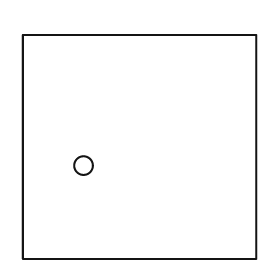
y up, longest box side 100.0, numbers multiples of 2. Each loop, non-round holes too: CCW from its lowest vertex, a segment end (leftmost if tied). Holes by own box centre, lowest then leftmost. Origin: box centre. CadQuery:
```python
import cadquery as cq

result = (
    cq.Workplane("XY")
    .moveTo(-50.0, -48.0)
    .lineTo(50.0, -48.0)
    .lineTo(50.0, 48.0)
    .lineTo(-50.0, 48.0)
    .close()
    .moveTo(-24.0, -8.0)
    .circle(4.0)
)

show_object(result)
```